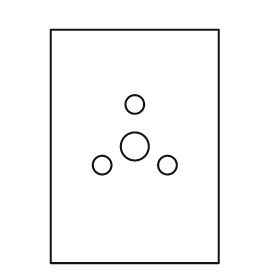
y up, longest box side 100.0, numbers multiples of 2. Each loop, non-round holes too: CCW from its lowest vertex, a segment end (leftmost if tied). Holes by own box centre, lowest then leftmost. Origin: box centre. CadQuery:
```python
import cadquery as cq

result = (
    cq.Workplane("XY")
    .moveTo(-36.0, -50.0)
    .lineTo(36.0, -50.0)
    .lineTo(36.0, 50.0)
    .lineTo(-36.0, 50.0)
    .close()
    .moveTo(-14.0, -8.0)
    .circle(4.0)
    .moveTo(14.0, -8.0)
    .circle(4.0)
    .moveTo(0.0, 0.0)
    .circle(6.0)
    .moveTo(0.0, 18.0)
    .circle(4.0)
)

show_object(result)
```